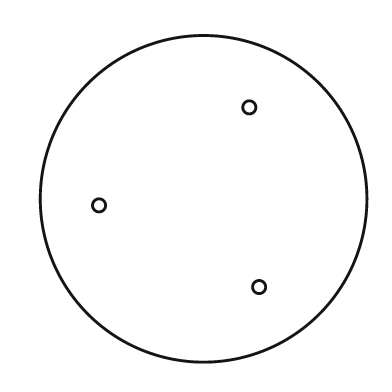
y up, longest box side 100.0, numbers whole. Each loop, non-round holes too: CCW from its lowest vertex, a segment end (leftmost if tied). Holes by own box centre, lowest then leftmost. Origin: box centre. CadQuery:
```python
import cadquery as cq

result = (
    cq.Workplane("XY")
    .moveTo(0.0, 0.0)
    .circle(50.0)
    .moveTo(17.0, -27.0)
    .circle(2.0)
    .moveTo(-32.0, -2.0)
    .circle(2.0)
    .moveTo(14.0, 28.0)
    .circle(2.0)
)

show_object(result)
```